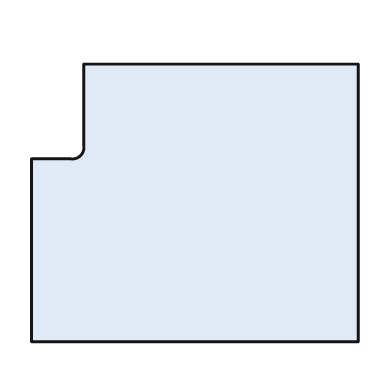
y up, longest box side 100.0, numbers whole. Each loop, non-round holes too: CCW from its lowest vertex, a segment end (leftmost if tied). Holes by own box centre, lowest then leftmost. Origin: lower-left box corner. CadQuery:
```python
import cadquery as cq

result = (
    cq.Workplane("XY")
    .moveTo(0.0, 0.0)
    .lineTo(100.0, 0.0)
    .lineTo(100.0, 85.0)
    .lineTo(16.0, 85.0)
    .lineTo(16.0, 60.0)
    .threePointArc((15.0, 57.0), (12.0, 56.0))
    .lineTo(0.0, 56.0)
    .close()
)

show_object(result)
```